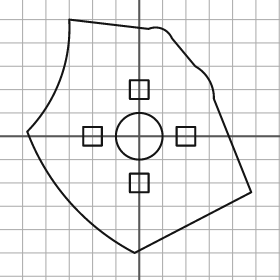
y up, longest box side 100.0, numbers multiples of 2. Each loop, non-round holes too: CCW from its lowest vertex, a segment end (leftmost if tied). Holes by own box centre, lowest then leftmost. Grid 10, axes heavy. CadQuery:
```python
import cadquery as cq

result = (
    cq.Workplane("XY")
    .moveTo(-2.0, -50.0)
    .lineTo(48.0, -24.0)
    .lineTo(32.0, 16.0)
    .threePointArc((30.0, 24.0), (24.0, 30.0))
    .lineTo(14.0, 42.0)
    .threePointArc((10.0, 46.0), (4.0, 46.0))
    .lineTo(-30.0, 50.0)
    .threePointArc((-34.0, 24.0), (-48.0, 2.0))
    .threePointArc((-30.0, -28.0), (-2.0, -50.0))
    .close()
    .moveTo(-4.0, -24.0)
    .lineTo(4.0, -24.0)
    .lineTo(4.0, -16.0)
    .lineTo(-4.0, -16.0)
    .close()
    .moveTo(-24.0, -4.0)
    .lineTo(-16.0, -4.0)
    .lineTo(-16.0, 4.0)
    .lineTo(-24.0, 4.0)
    .close()
    .moveTo(0.0, 0.0)
    .circle(10.0)
    .moveTo(16.0, -4.0)
    .lineTo(24.0, -4.0)
    .lineTo(24.0, 4.0)
    .lineTo(16.0, 4.0)
    .close()
    .moveTo(-4.0, 16.0)
    .lineTo(4.0, 16.0)
    .lineTo(4.0, 24.0)
    .lineTo(-4.0, 24.0)
    .close()
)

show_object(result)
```